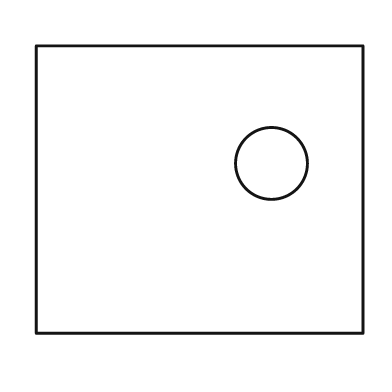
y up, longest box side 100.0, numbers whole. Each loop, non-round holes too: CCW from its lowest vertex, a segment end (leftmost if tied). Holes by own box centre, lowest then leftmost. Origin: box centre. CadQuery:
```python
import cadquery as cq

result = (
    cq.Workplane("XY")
    .moveTo(-50.0, -44.0)
    .lineTo(50.0, -44.0)
    .lineTo(50.0, 44.0)
    .lineTo(-50.0, 44.0)
    .close()
    .moveTo(22.0, 8.0)
    .circle(11.0)
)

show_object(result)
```